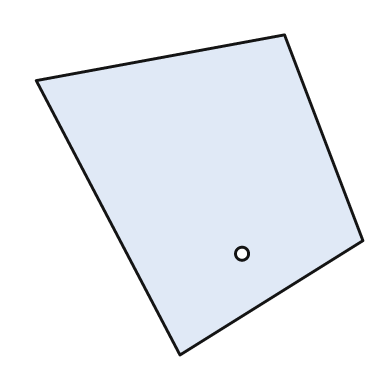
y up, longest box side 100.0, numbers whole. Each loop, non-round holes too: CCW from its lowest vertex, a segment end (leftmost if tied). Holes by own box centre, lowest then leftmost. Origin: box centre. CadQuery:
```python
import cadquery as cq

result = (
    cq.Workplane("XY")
    .moveTo(-6.0, -49.0)
    .lineTo(50.0, -14.0)
    .lineTo(26.0, 49.0)
    .lineTo(-50.0, 35.0)
    .close()
    .moveTo(13.0, -18.0)
    .circle(2.0)
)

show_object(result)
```